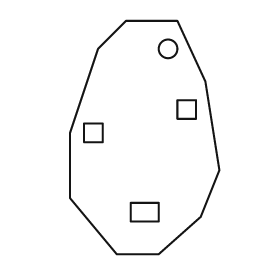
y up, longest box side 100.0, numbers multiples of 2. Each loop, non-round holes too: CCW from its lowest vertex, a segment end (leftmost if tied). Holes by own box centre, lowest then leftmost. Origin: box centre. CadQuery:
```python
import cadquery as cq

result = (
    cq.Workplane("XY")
    .moveTo(-12.0, -50.0)
    .lineTo(6.0, -50.0)
    .lineTo(24.0, -34.0)
    .lineTo(32.0, -14.0)
    .lineTo(26.0, 24.0)
    .lineTo(14.0, 50.0)
    .lineTo(-8.0, 50.0)
    .lineTo(-20.0, 38.0)
    .lineTo(-32.0, 2.0)
    .lineTo(-32.0, -26.0)
    .close()
    .moveTo(-6.0, -36.0)
    .lineTo(6.0, -36.0)
    .lineTo(6.0, -28.0)
    .lineTo(-6.0, -28.0)
    .close()
    .moveTo(-26.0, -2.0)
    .lineTo(-18.0, -2.0)
    .lineTo(-18.0, 6.0)
    .lineTo(-26.0, 6.0)
    .close()
    .moveTo(14.0, 8.0)
    .lineTo(22.0, 8.0)
    .lineTo(22.0, 16.0)
    .lineTo(14.0, 16.0)
    .close()
    .moveTo(10.0, 38.0)
    .circle(4.0)
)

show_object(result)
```